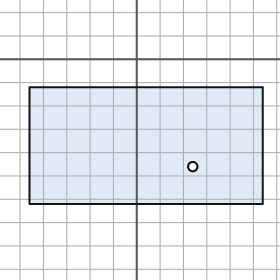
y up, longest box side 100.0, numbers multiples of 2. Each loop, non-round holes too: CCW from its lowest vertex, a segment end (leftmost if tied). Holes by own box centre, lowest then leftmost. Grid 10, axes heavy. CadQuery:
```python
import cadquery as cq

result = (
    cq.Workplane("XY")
    .moveTo(-46.0, -62.0)
    .lineTo(54.0, -62.0)
    .lineTo(54.0, -12.0)
    .lineTo(-46.0, -12.0)
    .close()
    .moveTo(24.0, -46.0)
    .circle(2.0)
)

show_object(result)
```